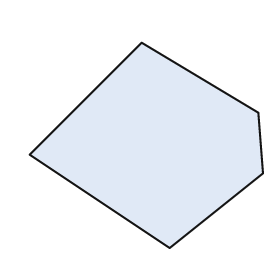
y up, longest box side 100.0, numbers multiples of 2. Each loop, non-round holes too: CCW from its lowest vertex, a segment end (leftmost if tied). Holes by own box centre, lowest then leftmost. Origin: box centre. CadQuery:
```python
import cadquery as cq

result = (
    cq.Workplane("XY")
    .moveTo(10.0, -44.0)
    .lineTo(50.0, -12.0)
    .lineTo(48.0, 14.0)
    .lineTo(-2.0, 44.0)
    .lineTo(-50.0, -4.0)
    .close()
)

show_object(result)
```